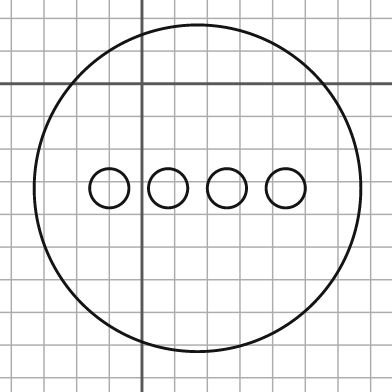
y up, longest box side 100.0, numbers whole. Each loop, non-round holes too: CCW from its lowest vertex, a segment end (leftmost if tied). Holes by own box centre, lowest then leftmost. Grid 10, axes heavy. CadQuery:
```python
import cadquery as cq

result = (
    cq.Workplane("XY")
    .moveTo(17.0, -32.0)
    .circle(50.0)
    .moveTo(-10.0, -32.0)
    .circle(6.0)
    .moveTo(8.0, -32.0)
    .circle(6.0)
    .moveTo(26.0, -32.0)
    .circle(6.0)
    .moveTo(44.0, -32.0)
    .circle(6.0)
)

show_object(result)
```